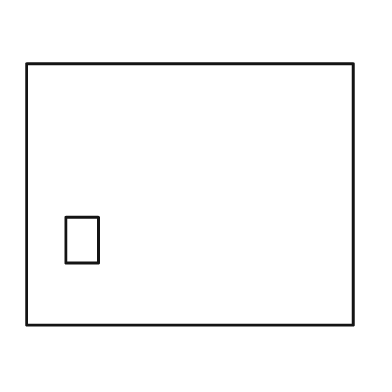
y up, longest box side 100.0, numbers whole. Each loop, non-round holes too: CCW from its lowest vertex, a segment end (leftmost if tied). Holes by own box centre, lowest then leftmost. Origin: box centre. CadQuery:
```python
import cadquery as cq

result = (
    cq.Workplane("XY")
    .moveTo(-50.0, -40.0)
    .lineTo(50.0, -40.0)
    .lineTo(50.0, 40.0)
    .lineTo(-50.0, 40.0)
    .close()
    .moveTo(-38.0, -21.0)
    .lineTo(-28.0, -21.0)
    .lineTo(-28.0, -7.0)
    .lineTo(-38.0, -7.0)
    .close()
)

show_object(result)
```